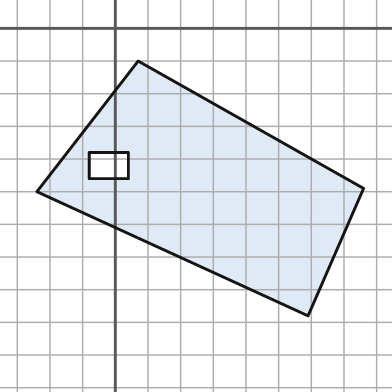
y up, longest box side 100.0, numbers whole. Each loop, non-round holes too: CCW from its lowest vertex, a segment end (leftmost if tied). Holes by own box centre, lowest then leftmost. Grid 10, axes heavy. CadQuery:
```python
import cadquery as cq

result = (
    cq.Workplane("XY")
    .moveTo(59.0, -88.0)
    .lineTo(76.0, -49.0)
    .lineTo(7.0, -10.0)
    .lineTo(-24.0, -50.0)
    .close()
    .moveTo(-8.0, -46.0)
    .lineTo(4.0, -46.0)
    .lineTo(4.0, -38.0)
    .lineTo(-8.0, -38.0)
    .close()
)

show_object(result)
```